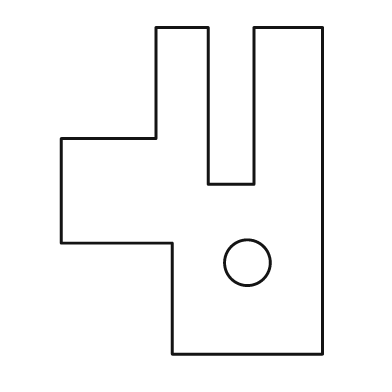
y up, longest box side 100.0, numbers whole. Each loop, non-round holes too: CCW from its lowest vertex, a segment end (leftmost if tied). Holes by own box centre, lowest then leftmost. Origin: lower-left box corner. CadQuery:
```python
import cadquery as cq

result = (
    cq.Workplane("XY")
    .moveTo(34.0, 0.0)
    .lineTo(80.0, 0.0)
    .lineTo(80.0, 100.0)
    .lineTo(59.0, 100.0)
    .lineTo(59.0, 52.0)
    .lineTo(45.0, 52.0)
    .lineTo(45.0, 100.0)
    .lineTo(29.0, 100.0)
    .lineTo(29.0, 66.0)
    .lineTo(0.0, 66.0)
    .lineTo(0.0, 34.0)
    .lineTo(34.0, 34.0)
    .close()
    .moveTo(57.0, 28.0)
    .circle(7.0)
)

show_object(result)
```